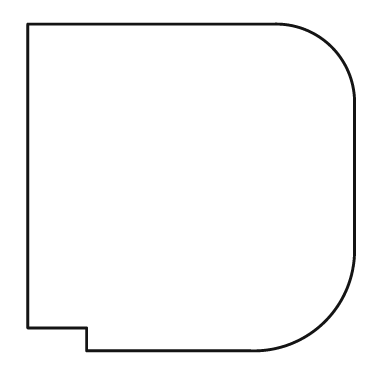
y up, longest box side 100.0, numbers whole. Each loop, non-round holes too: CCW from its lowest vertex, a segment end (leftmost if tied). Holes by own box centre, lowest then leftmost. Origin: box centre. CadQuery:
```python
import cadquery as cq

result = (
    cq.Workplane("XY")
    .moveTo(-32.0, -50.0)
    .lineTo(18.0, -50.0)
    .threePointArc((41.0, -41.0), (50.0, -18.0))
    .lineTo(50.0, 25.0)
    .threePointArc((43.0, 43.0), (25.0, 50.0))
    .lineTo(-50.0, 50.0)
    .lineTo(-50.0, -43.0)
    .lineTo(-32.0, -43.0)
    .close()
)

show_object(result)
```